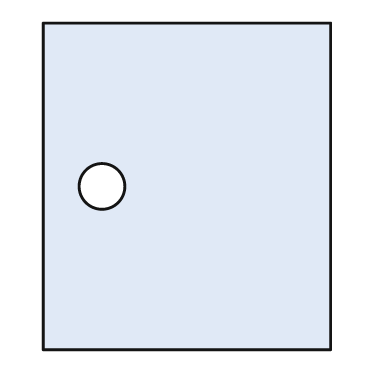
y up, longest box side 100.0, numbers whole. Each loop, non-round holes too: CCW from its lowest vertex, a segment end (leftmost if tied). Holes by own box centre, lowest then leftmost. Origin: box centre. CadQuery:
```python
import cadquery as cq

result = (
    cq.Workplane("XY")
    .moveTo(-44.0, -50.0)
    .lineTo(44.0, -50.0)
    .lineTo(44.0, 50.0)
    .lineTo(-44.0, 50.0)
    .close()
    .moveTo(-26.0, 0.0)
    .circle(7.0)
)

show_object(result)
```